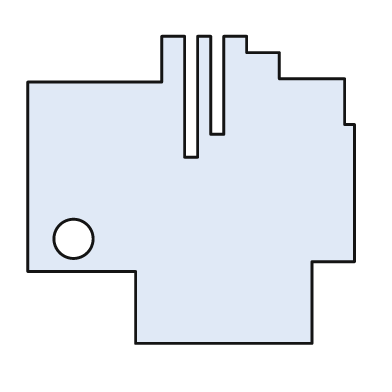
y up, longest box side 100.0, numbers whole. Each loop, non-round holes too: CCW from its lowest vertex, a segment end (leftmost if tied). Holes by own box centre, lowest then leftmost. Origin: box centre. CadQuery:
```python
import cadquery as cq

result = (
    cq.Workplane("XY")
    .moveTo(-17.0, -47.0)
    .lineTo(37.0, -47.0)
    .lineTo(37.0, -22.0)
    .lineTo(50.0, -22.0)
    .lineTo(50.0, 20.0)
    .lineTo(47.0, 20.0)
    .lineTo(47.0, 34.0)
    .lineTo(27.0, 34.0)
    .lineTo(27.0, 42.0)
    .lineTo(17.0, 42.0)
    .lineTo(17.0, 47.0)
    .lineTo(10.0, 47.0)
    .lineTo(10.0, 17.0)
    .lineTo(6.0, 17.0)
    .lineTo(6.0, 47.0)
    .lineTo(2.0, 47.0)
    .lineTo(2.0, 10.0)
    .lineTo(-2.0, 10.0)
    .lineTo(-2.0, 47.0)
    .lineTo(-9.0, 47.0)
    .lineTo(-9.0, 33.0)
    .lineTo(-50.0, 33.0)
    .lineTo(-50.0, -25.0)
    .lineTo(-17.0, -25.0)
    .close()
    .moveTo(-36.0, -15.0)
    .circle(6.0)
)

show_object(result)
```